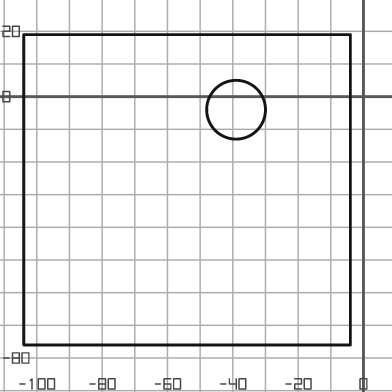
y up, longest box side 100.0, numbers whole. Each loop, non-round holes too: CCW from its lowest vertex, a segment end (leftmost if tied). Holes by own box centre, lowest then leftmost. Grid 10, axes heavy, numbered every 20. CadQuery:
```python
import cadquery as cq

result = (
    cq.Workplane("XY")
    .moveTo(-104.0, -76.0)
    .lineTo(-4.0, -76.0)
    .lineTo(-4.0, 19.0)
    .lineTo(-104.0, 19.0)
    .close()
    .moveTo(-39.0, -4.0)
    .circle(9.0)
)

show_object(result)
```